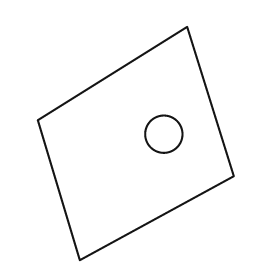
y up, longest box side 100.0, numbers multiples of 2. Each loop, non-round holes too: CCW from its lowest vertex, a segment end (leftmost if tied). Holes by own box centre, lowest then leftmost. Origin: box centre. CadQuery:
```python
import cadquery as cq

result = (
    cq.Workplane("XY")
    .moveTo(-24.0, -50.0)
    .lineTo(42.0, -14.0)
    .lineTo(22.0, 50.0)
    .lineTo(-42.0, 10.0)
    .close()
    .moveTo(12.0, 4.0)
    .circle(8.0)
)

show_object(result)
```